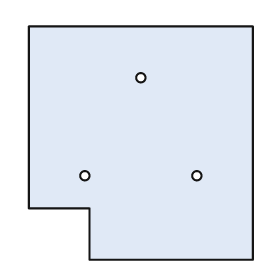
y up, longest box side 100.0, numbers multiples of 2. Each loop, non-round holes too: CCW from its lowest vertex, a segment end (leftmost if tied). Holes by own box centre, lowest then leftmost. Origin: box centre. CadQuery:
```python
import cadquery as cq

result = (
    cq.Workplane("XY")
    .moveTo(-22.0, -50.0)
    .lineTo(48.0, -50.0)
    .lineTo(48.0, 50.0)
    .lineTo(-48.0, 50.0)
    .lineTo(-48.0, -28.0)
    .lineTo(-22.0, -28.0)
    .close()
    .moveTo(-24.0, -14.0)
    .circle(2.0)
    .moveTo(24.0, -14.0)
    .circle(2.0)
    .moveTo(0.0, 28.0)
    .circle(2.0)
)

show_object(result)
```